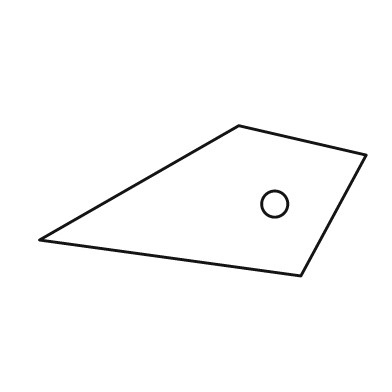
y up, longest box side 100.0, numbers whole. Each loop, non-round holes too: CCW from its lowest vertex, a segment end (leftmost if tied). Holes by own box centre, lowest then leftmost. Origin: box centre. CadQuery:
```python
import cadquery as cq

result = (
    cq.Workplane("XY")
    .moveTo(30.0, -23.0)
    .lineTo(50.0, 14.0)
    .lineTo(11.0, 23.0)
    .lineTo(-50.0, -12.0)
    .close()
    .moveTo(22.0, -1.0)
    .circle(4.0)
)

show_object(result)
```